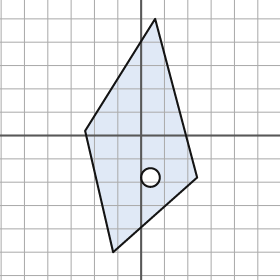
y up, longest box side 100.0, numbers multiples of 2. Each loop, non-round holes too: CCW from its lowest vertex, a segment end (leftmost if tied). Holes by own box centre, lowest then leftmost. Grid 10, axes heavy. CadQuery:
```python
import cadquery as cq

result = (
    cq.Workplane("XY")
    .moveTo(-12.0, -50.0)
    .lineTo(24.0, -18.0)
    .lineTo(6.0, 50.0)
    .lineTo(-24.0, 2.0)
    .close()
    .moveTo(4.0, -18.0)
    .circle(4.0)
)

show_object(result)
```